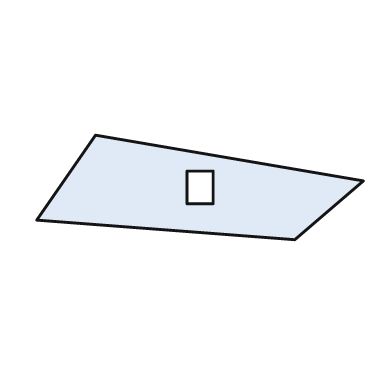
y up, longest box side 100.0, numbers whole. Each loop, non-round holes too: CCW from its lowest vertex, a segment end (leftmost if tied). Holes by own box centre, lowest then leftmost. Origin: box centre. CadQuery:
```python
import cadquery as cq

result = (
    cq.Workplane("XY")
    .moveTo(29.0, -16.0)
    .lineTo(50.0, 2.0)
    .lineTo(-32.0, 16.0)
    .lineTo(-50.0, -10.0)
    .close()
    .moveTo(-4.0, -5.0)
    .lineTo(4.0, -5.0)
    .lineTo(4.0, 5.0)
    .lineTo(-4.0, 5.0)
    .close()
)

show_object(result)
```